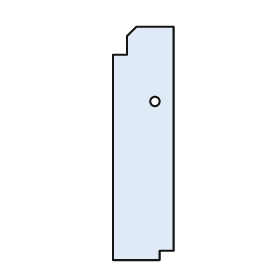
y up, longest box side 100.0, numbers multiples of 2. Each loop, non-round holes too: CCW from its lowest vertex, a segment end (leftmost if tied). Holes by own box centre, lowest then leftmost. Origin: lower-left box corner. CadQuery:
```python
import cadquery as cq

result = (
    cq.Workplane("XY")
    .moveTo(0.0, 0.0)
    .lineTo(20.0, 0.0)
    .lineTo(20.0, 4.0)
    .lineTo(26.0, 4.0)
    .lineTo(26.0, 100.0)
    .lineTo(10.0, 100.0)
    .lineTo(6.0, 96.0)
    .lineTo(6.0, 88.0)
    .lineTo(0.0, 88.0)
    .close()
    .moveTo(18.0, 68.0)
    .circle(2.0)
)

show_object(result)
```